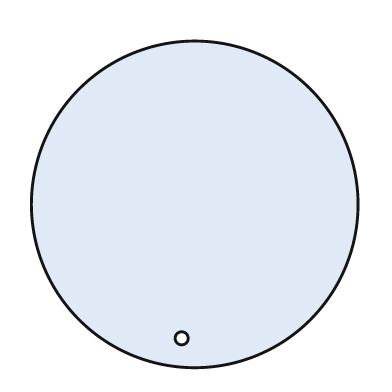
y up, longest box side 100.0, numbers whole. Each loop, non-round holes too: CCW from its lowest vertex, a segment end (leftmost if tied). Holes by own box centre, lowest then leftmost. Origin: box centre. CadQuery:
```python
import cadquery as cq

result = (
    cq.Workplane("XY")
    .moveTo(0.0, 0.0)
    .circle(50.0)
    .moveTo(-4.0, -41.0)
    .circle(2.0)
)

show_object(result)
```